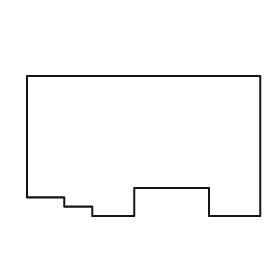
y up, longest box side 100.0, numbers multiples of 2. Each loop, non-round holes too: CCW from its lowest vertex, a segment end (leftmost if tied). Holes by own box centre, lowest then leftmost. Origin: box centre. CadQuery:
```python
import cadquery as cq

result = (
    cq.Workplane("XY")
    .moveTo(-22.0, -30.0)
    .lineTo(-4.0, -30.0)
    .lineTo(-4.0, -18.0)
    .lineTo(28.0, -18.0)
    .lineTo(28.0, -30.0)
    .lineTo(50.0, -30.0)
    .lineTo(50.0, 30.0)
    .lineTo(-50.0, 30.0)
    .lineTo(-50.0, -22.0)
    .lineTo(-34.0, -22.0)
    .lineTo(-34.0, -26.0)
    .lineTo(-22.0, -26.0)
    .close()
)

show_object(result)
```